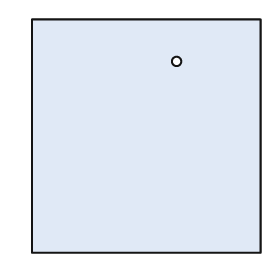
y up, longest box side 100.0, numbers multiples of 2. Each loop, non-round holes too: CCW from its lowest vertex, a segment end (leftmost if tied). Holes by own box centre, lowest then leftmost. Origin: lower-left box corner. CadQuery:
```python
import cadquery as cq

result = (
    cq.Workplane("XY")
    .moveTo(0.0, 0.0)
    .lineTo(98.0, 0.0)
    .lineTo(98.0, 100.0)
    .lineTo(0.0, 100.0)
    .close()
    .moveTo(62.0, 82.0)
    .circle(2.0)
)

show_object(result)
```